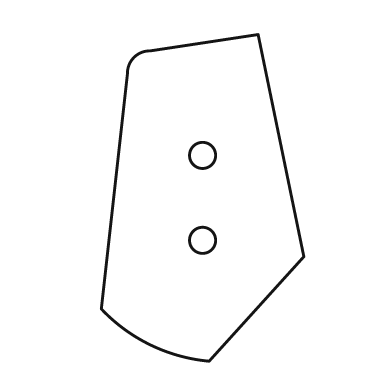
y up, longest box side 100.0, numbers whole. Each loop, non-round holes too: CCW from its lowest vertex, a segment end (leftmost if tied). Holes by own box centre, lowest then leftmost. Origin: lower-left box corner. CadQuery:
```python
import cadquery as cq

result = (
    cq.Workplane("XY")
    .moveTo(33.0, 0.0)
    .lineTo(62.0, 32.0)
    .lineTo(48.0, 100.0)
    .lineTo(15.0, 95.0)
    .threePointArc((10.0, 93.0), (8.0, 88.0))
    .lineTo(0.0, 16.0)
    .threePointArc((15.0, 5.0), (33.0, 0.0))
    .close()
    .moveTo(31.0, 37.0)
    .circle(4.0)
    .moveTo(31.0, 63.0)
    .circle(4.0)
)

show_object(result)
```